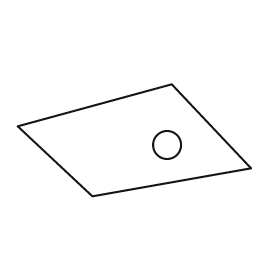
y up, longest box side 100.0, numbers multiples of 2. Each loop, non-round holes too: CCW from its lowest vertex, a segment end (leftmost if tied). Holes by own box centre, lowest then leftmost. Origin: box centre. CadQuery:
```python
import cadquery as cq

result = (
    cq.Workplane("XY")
    .moveTo(-18.0, -24.0)
    .lineTo(50.0, -12.0)
    .lineTo(16.0, 24.0)
    .lineTo(-50.0, 6.0)
    .close()
    .moveTo(14.0, -2.0)
    .circle(6.0)
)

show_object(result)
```